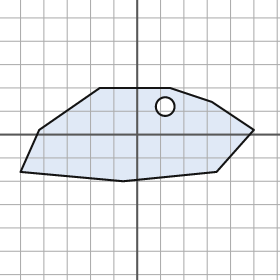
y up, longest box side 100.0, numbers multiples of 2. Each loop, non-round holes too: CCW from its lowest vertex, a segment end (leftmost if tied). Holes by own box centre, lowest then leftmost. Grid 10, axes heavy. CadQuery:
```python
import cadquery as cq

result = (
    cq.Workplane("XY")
    .moveTo(-6.0, -20.0)
    .lineTo(34.0, -16.0)
    .lineTo(50.0, 2.0)
    .lineTo(32.0, 14.0)
    .lineTo(14.0, 20.0)
    .lineTo(-16.0, 20.0)
    .lineTo(-42.0, 2.0)
    .lineTo(-50.0, -16.0)
    .close()
    .moveTo(12.0, 12.0)
    .circle(4.0)
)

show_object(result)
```